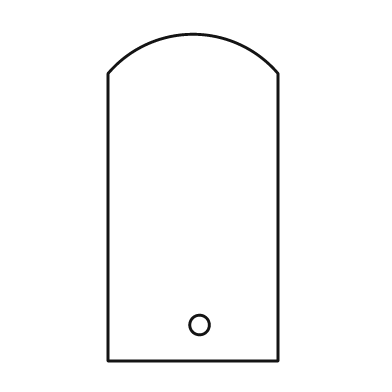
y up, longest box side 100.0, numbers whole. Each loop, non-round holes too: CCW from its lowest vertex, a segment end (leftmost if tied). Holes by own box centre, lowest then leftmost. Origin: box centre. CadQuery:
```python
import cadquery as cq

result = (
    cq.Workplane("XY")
    .moveTo(-26.0, -50.0)
    .lineTo(26.0, -50.0)
    .lineTo(26.0, 38.0)
    .threePointArc((0.0, 50.0), (-26.0, 38.0))
    .close()
    .moveTo(2.0, -39.0)
    .circle(3.0)
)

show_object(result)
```